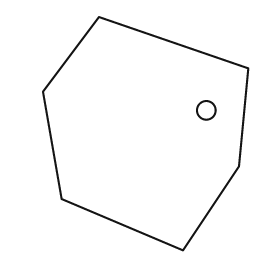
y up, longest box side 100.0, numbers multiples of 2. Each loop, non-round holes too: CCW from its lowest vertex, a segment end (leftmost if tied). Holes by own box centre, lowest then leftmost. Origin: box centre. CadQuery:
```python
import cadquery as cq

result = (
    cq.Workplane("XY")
    .moveTo(16.0, -50.0)
    .lineTo(40.0, -14.0)
    .lineTo(44.0, 28.0)
    .lineTo(-20.0, 50.0)
    .lineTo(-44.0, 18.0)
    .lineTo(-36.0, -28.0)
    .close()
    .moveTo(26.0, 10.0)
    .circle(4.0)
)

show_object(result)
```